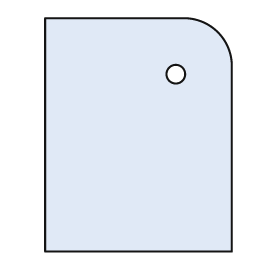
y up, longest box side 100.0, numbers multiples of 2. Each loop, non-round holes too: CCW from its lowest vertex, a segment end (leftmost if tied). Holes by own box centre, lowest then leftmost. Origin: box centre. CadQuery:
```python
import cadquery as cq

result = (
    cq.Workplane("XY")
    .moveTo(-40.0, -50.0)
    .lineTo(40.0, -50.0)
    .lineTo(40.0, 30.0)
    .threePointArc((34.0, 44.0), (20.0, 50.0))
    .lineTo(-40.0, 50.0)
    .close()
    .moveTo(16.0, 26.0)
    .circle(4.0)
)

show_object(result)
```